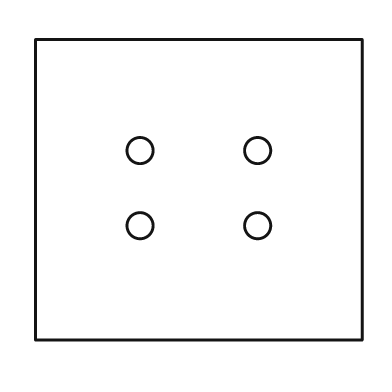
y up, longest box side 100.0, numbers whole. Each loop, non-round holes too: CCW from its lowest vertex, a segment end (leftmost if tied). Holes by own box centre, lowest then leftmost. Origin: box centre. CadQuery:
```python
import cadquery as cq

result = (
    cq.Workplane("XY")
    .moveTo(-50.0, -46.0)
    .lineTo(50.0, -46.0)
    .lineTo(50.0, 46.0)
    .lineTo(-50.0, 46.0)
    .close()
    .moveTo(-18.0, -11.0)
    .circle(4.0)
    .moveTo(18.0, -11.0)
    .circle(4.0)
    .moveTo(-18.0, 12.0)
    .circle(4.0)
    .moveTo(18.0, 12.0)
    .circle(4.0)
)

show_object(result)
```